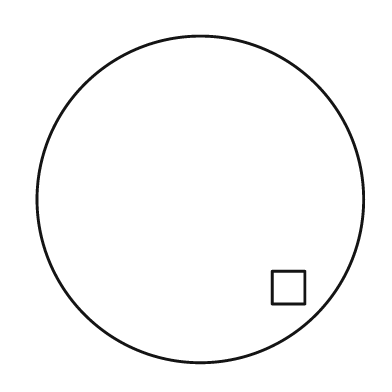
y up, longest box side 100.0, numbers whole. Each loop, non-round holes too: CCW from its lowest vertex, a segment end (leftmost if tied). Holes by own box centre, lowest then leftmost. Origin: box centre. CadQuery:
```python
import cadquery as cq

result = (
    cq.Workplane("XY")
    .moveTo(0.0, 0.0)
    .circle(50.0)
    .moveTo(22.0, -32.0)
    .lineTo(32.0, -32.0)
    .lineTo(32.0, -22.0)
    .lineTo(22.0, -22.0)
    .close()
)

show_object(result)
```